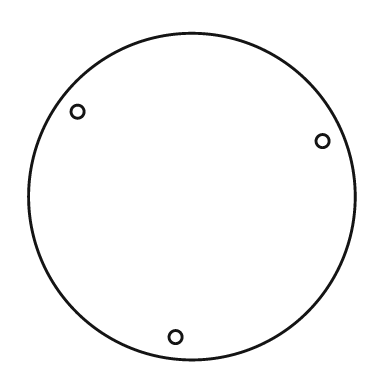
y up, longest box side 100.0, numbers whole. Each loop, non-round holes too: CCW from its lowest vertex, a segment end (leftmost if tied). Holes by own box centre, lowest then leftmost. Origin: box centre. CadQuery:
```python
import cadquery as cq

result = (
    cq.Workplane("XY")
    .moveTo(0.0, 0.0)
    .circle(50.0)
    .moveTo(-5.0, -43.0)
    .circle(2.0)
    .moveTo(40.0, 17.0)
    .circle(2.0)
    .moveTo(-35.0, 26.0)
    .circle(2.0)
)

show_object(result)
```